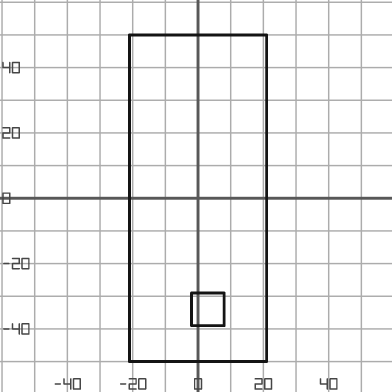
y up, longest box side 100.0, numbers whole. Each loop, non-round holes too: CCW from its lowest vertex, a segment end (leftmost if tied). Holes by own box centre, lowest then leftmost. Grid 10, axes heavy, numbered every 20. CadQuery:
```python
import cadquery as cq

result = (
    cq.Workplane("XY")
    .moveTo(-21.0, -50.0)
    .lineTo(21.0, -50.0)
    .lineTo(21.0, 50.0)
    .lineTo(-21.0, 50.0)
    .close()
    .moveTo(-2.0, -39.0)
    .lineTo(8.0, -39.0)
    .lineTo(8.0, -29.0)
    .lineTo(-2.0, -29.0)
    .close()
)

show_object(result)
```